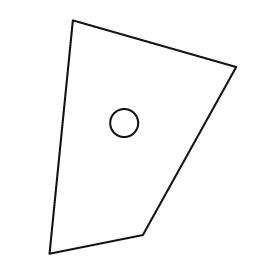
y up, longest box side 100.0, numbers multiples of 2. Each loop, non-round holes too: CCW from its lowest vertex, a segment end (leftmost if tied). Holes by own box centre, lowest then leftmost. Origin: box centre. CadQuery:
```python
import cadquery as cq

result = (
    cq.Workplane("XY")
    .moveTo(-40.0, -50.0)
    .lineTo(0.0, -42.0)
    .lineTo(40.0, 30.0)
    .lineTo(-30.0, 50.0)
    .close()
    .moveTo(-8.0, 6.0)
    .circle(6.0)
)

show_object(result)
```